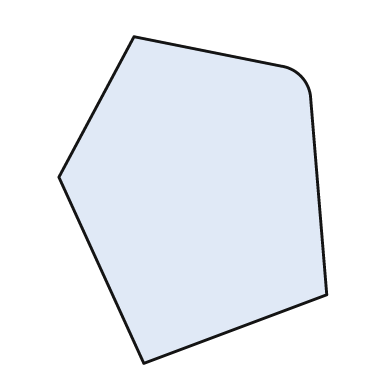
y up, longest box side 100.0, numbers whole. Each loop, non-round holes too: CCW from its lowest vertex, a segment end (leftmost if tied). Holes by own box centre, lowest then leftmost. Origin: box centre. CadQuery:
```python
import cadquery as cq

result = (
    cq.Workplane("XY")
    .moveTo(-15.0, -50.0)
    .lineTo(41.0, -29.0)
    .lineTo(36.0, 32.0)
    .threePointArc((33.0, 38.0), (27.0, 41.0))
    .lineTo(-18.0, 50.0)
    .lineTo(-41.0, 7.0)
    .close()
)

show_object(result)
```